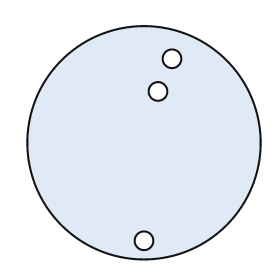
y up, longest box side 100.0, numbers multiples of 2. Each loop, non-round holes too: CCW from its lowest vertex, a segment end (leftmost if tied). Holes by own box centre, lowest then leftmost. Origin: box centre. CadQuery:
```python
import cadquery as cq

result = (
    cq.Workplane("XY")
    .moveTo(0.0, 0.0)
    .circle(50.0)
    .moveTo(0.0, -42.0)
    .circle(4.0)
    .moveTo(6.0, 22.0)
    .circle(4.0)
    .moveTo(12.0, 36.0)
    .circle(4.0)
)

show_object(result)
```